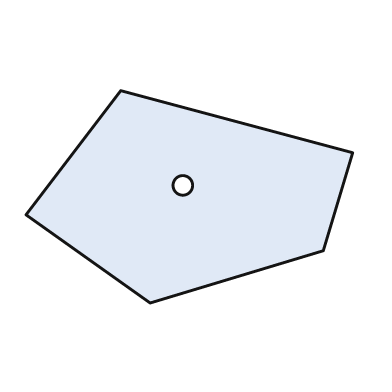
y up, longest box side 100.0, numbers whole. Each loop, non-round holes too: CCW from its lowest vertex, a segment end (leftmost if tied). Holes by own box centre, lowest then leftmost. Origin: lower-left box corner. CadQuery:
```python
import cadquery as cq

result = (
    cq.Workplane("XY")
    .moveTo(38.0, 0.0)
    .lineTo(91.0, 16.0)
    .lineTo(100.0, 46.0)
    .lineTo(29.0, 65.0)
    .lineTo(0.0, 27.0)
    .close()
    .moveTo(48.0, 36.0)
    .circle(3.0)
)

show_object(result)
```